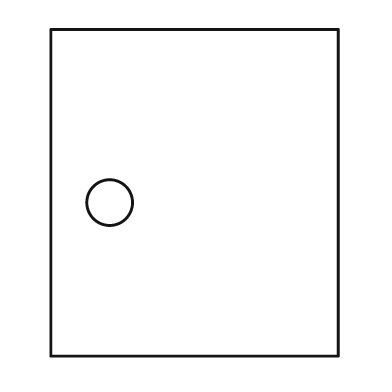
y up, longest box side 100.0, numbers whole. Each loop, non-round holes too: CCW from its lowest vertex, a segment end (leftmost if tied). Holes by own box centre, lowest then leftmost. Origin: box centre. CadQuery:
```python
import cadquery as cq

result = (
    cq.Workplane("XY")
    .moveTo(-44.0, -50.0)
    .lineTo(44.0, -50.0)
    .lineTo(44.0, 50.0)
    .lineTo(-44.0, 50.0)
    .close()
    .moveTo(-26.0, -3.0)
    .circle(7.0)
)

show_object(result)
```